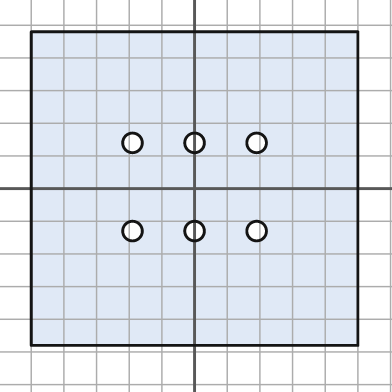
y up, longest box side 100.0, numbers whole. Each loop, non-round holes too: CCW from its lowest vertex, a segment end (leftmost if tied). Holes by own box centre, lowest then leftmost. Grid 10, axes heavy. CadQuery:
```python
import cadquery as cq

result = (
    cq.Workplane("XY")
    .moveTo(-50.0, -48.0)
    .lineTo(50.0, -48.0)
    .lineTo(50.0, 48.0)
    .lineTo(-50.0, 48.0)
    .close()
    .moveTo(-19.0, -13.0)
    .circle(3.0)
    .moveTo(0.0, -13.0)
    .circle(3.0)
    .moveTo(19.0, -13.0)
    .circle(3.0)
    .moveTo(-19.0, 14.0)
    .circle(3.0)
    .moveTo(0.0, 14.0)
    .circle(3.0)
    .moveTo(19.0, 14.0)
    .circle(3.0)
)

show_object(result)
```